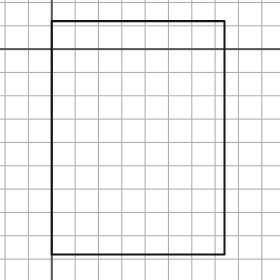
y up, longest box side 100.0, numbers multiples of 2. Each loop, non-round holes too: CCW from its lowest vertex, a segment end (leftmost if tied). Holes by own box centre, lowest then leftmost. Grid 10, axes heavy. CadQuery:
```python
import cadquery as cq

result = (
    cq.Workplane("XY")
    .moveTo(0.0, -88.0)
    .lineTo(74.0, -88.0)
    .lineTo(74.0, 12.0)
    .lineTo(0.0, 12.0)
    .close()
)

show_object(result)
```